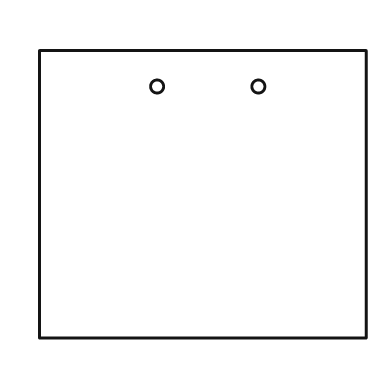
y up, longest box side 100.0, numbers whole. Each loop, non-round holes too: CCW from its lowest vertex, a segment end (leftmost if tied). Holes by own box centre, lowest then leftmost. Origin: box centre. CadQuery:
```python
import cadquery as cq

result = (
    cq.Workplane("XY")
    .moveTo(-50.0, -44.0)
    .lineTo(50.0, -44.0)
    .lineTo(50.0, 44.0)
    .lineTo(-50.0, 44.0)
    .close()
    .moveTo(-14.0, 33.0)
    .circle(2.0)
    .moveTo(17.0, 33.0)
    .circle(2.0)
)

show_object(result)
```